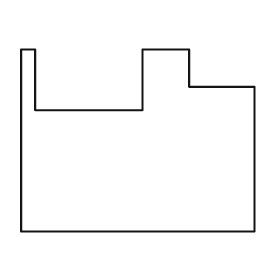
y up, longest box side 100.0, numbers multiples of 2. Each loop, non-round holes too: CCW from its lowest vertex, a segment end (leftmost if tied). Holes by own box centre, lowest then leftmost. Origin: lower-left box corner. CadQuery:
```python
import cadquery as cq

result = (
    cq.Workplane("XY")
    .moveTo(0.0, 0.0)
    .lineTo(100.0, 0.0)
    .lineTo(100.0, 62.0)
    .lineTo(72.0, 62.0)
    .lineTo(72.0, 78.0)
    .lineTo(52.0, 78.0)
    .lineTo(52.0, 52.0)
    .lineTo(6.0, 52.0)
    .lineTo(6.0, 78.0)
    .lineTo(0.0, 78.0)
    .close()
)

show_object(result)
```